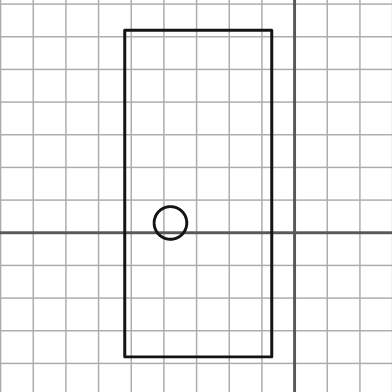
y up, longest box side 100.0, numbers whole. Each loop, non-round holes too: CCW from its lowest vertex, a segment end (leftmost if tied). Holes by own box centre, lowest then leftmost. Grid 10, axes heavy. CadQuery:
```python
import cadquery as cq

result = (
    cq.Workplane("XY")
    .moveTo(-52.0, -38.0)
    .lineTo(-7.0, -38.0)
    .lineTo(-7.0, 62.0)
    .lineTo(-52.0, 62.0)
    .close()
    .moveTo(-38.0, 3.0)
    .circle(5.0)
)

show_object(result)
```